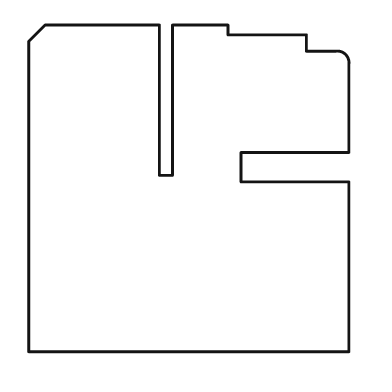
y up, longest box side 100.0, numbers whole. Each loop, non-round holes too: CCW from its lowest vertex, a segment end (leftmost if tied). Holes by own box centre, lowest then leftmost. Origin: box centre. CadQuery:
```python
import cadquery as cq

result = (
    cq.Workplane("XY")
    .moveTo(-49.0, -50.0)
    .lineTo(49.0, -50.0)
    .lineTo(49.0, 2.0)
    .lineTo(16.0, 2.0)
    .lineTo(16.0, 11.0)
    .lineTo(49.0, 11.0)
    .lineTo(49.0, 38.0)
    .threePointArc((48.0, 41.0), (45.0, 42.0))
    .lineTo(36.0, 42.0)
    .lineTo(36.0, 47.0)
    .lineTo(12.0, 47.0)
    .lineTo(12.0, 50.0)
    .lineTo(-5.0, 50.0)
    .lineTo(-5.0, 4.0)
    .lineTo(-9.0, 4.0)
    .lineTo(-9.0, 50.0)
    .lineTo(-44.0, 50.0)
    .lineTo(-49.0, 45.0)
    .close()
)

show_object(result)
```